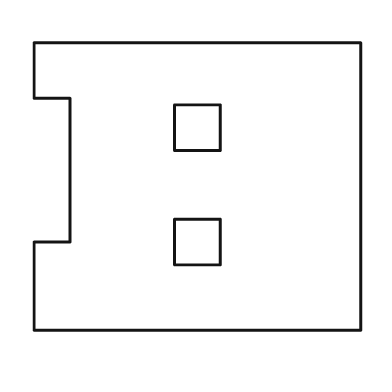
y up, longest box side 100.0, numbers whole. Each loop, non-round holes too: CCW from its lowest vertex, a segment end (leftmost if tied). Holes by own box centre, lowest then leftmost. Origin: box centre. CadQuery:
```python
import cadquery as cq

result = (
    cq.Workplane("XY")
    .moveTo(-50.0, -44.0)
    .lineTo(50.0, -44.0)
    .lineTo(50.0, 44.0)
    .lineTo(-50.0, 44.0)
    .lineTo(-50.0, 27.0)
    .lineTo(-39.0, 27.0)
    .lineTo(-39.0, -17.0)
    .lineTo(-50.0, -17.0)
    .close()
    .moveTo(-7.0, -24.0)
    .lineTo(7.0, -24.0)
    .lineTo(7.0, -10.0)
    .lineTo(-7.0, -10.0)
    .close()
    .moveTo(-7.0, 11.0)
    .lineTo(7.0, 11.0)
    .lineTo(7.0, 25.0)
    .lineTo(-7.0, 25.0)
    .close()
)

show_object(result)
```